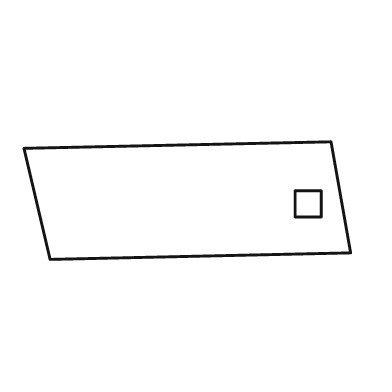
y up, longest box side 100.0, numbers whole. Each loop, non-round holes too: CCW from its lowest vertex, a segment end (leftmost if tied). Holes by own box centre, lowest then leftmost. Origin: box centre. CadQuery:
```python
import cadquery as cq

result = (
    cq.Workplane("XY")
    .moveTo(-42.0, -18.0)
    .lineTo(50.0, -16.0)
    .lineTo(44.0, 18.0)
    .lineTo(-50.0, 16.0)
    .close()
    .moveTo(33.0, -5.0)
    .lineTo(41.0, -5.0)
    .lineTo(41.0, 3.0)
    .lineTo(33.0, 3.0)
    .close()
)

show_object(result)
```